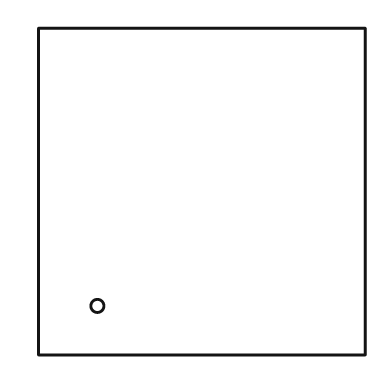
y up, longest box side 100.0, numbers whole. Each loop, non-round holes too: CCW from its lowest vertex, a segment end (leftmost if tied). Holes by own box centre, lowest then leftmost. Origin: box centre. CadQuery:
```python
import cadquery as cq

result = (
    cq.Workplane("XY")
    .moveTo(-50.0, -50.0)
    .lineTo(50.0, -50.0)
    .lineTo(50.0, 50.0)
    .lineTo(-50.0, 50.0)
    .close()
    .moveTo(-32.0, -35.0)
    .circle(2.0)
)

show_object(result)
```